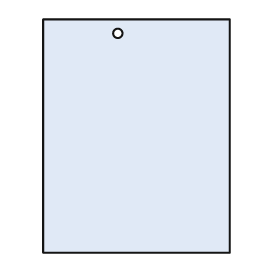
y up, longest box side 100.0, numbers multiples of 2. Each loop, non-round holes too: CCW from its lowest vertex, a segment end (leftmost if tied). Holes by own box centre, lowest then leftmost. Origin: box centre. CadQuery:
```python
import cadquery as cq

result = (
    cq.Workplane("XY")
    .moveTo(-40.0, -50.0)
    .lineTo(40.0, -50.0)
    .lineTo(40.0, 50.0)
    .lineTo(-40.0, 50.0)
    .close()
    .moveTo(-8.0, 44.0)
    .circle(2.0)
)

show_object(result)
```